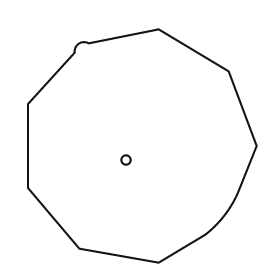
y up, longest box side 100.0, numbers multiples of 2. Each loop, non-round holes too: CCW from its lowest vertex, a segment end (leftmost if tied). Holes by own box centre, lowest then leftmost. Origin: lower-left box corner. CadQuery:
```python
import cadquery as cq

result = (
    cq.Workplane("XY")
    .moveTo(56.0, 0.0)
    .lineTo(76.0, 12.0)
    .threePointArc((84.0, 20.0), (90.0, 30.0))
    .lineTo(98.0, 50.0)
    .lineTo(86.0, 82.0)
    .lineTo(56.0, 100.0)
    .lineTo(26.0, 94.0)
    .threePointArc((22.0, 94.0), (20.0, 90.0))
    .lineTo(0.0, 68.0)
    .lineTo(0.0, 32.0)
    .lineTo(22.0, 6.0)
    .close()
    .moveTo(42.0, 44.0)
    .circle(2.0)
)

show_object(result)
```